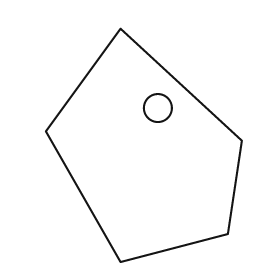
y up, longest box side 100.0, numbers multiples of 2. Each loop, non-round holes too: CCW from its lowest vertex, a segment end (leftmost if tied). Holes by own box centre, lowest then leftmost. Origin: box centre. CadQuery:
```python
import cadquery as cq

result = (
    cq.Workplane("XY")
    .moveTo(-10.0, -50.0)
    .lineTo(36.0, -38.0)
    .lineTo(42.0, 2.0)
    .lineTo(-10.0, 50.0)
    .lineTo(-42.0, 6.0)
    .close()
    .moveTo(6.0, 16.0)
    .circle(6.0)
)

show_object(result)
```